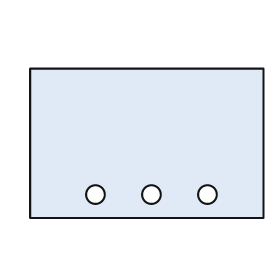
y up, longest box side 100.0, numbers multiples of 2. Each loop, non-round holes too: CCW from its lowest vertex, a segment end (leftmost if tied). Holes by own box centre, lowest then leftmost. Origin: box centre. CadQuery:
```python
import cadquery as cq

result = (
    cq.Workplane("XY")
    .moveTo(-50.0, -32.0)
    .lineTo(50.0, -32.0)
    .lineTo(50.0, 32.0)
    .lineTo(-50.0, 32.0)
    .close()
    .moveTo(-22.0, -22.0)
    .circle(4.0)
    .moveTo(2.0, -22.0)
    .circle(4.0)
    .moveTo(26.0, -22.0)
    .circle(4.0)
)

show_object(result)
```